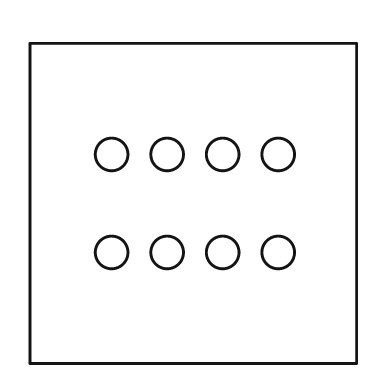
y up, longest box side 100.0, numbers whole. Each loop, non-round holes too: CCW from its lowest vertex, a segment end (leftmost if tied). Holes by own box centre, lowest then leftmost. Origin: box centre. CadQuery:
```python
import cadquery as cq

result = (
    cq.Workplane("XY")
    .moveTo(-50.0, -49.0)
    .lineTo(50.0, -49.0)
    .lineTo(50.0, 49.0)
    .lineTo(-50.0, 49.0)
    .close()
    .moveTo(-25.0, -15.0)
    .circle(5.0)
    .moveTo(-8.0, -15.0)
    .circle(5.0)
    .moveTo(9.0, -15.0)
    .circle(5.0)
    .moveTo(26.0, -15.0)
    .circle(5.0)
    .moveTo(-25.0, 15.0)
    .circle(5.0)
    .moveTo(-8.0, 15.0)
    .circle(5.0)
    .moveTo(9.0, 15.0)
    .circle(5.0)
    .moveTo(26.0, 15.0)
    .circle(5.0)
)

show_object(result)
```